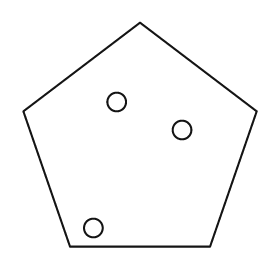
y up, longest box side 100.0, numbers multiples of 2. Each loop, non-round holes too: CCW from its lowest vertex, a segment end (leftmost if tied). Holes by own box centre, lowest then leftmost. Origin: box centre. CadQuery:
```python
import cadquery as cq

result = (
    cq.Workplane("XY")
    .moveTo(-30.0, -48.0)
    .lineTo(30.0, -48.0)
    .lineTo(50.0, 10.0)
    .lineTo(0.0, 48.0)
    .lineTo(-50.0, 10.0)
    .close()
    .moveTo(-20.0, -40.0)
    .circle(4.0)
    .moveTo(18.0, 2.0)
    .circle(4.0)
    .moveTo(-10.0, 14.0)
    .circle(4.0)
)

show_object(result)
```